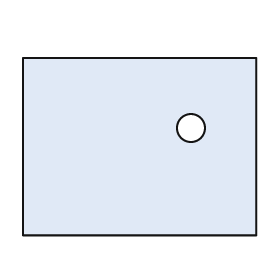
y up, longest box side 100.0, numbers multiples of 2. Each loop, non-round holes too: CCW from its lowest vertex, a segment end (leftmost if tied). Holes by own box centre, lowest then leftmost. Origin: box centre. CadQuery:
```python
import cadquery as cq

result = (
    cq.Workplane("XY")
    .moveTo(-50.0, -38.0)
    .lineTo(50.0, -38.0)
    .lineTo(50.0, 38.0)
    .lineTo(-50.0, 38.0)
    .close()
    .moveTo(22.0, 8.0)
    .circle(6.0)
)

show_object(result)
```